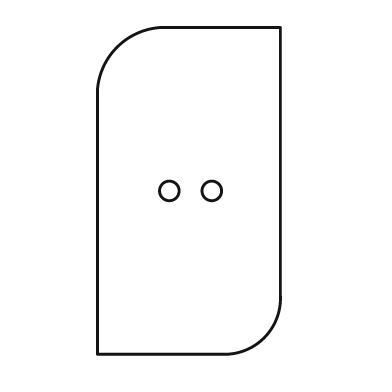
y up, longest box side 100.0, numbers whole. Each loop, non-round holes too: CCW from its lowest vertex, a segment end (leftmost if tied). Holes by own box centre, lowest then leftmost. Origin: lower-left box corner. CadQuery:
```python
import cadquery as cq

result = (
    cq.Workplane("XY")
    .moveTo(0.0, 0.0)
    .lineTo(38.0, 0.0)
    .threePointArc((51.0, 5.0), (56.0, 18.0))
    .lineTo(56.0, 100.0)
    .lineTo(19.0, 100.0)
    .threePointArc((6.0, 94.0), (0.0, 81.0))
    .close()
    .moveTo(22.0, 50.0)
    .circle(3.0)
    .moveTo(35.0, 50.0)
    .circle(3.0)
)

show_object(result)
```